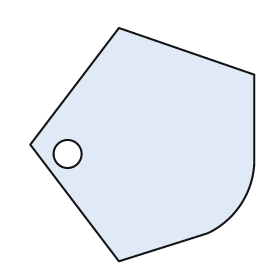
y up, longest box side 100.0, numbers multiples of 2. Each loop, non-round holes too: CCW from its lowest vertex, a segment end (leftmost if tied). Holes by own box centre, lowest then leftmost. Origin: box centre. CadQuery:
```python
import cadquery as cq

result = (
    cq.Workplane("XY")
    .moveTo(-10.0, -50.0)
    .lineTo(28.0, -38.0)
    .threePointArc((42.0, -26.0), (48.0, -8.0))
    .lineTo(48.0, 30.0)
    .lineTo(-10.0, 50.0)
    .lineTo(-48.0, 0.0)
    .close()
    .moveTo(-32.0, -4.0)
    .circle(6.0)
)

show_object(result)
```